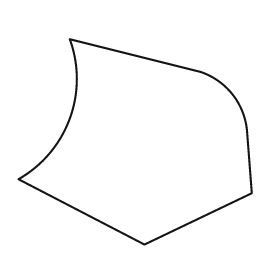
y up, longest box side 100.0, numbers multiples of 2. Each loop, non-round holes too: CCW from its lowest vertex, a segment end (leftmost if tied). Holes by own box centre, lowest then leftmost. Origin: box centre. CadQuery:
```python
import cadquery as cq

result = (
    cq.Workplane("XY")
    .moveTo(4.0, -44.0)
    .lineTo(50.0, -22.0)
    .lineTo(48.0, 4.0)
    .threePointArc((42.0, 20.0), (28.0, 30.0))
    .lineTo(-28.0, 44.0)
    .threePointArc((-28.0, 10.0), (-50.0, -16.0))
    .close()
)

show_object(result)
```